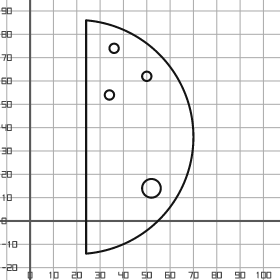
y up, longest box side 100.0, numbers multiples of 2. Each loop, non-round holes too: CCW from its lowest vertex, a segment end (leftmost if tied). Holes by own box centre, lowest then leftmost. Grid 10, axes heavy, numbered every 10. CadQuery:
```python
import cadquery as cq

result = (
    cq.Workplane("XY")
    .moveTo(24.0, -14.0)
    .threePointArc((70.0, 36.0), (24.0, 86.0))
    .close()
    .moveTo(52.0, 14.0)
    .circle(4.0)
    .moveTo(34.0, 54.0)
    .circle(2.0)
    .moveTo(50.0, 62.0)
    .circle(2.0)
    .moveTo(36.0, 74.0)
    .circle(2.0)
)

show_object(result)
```